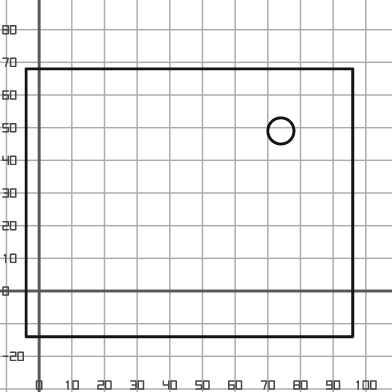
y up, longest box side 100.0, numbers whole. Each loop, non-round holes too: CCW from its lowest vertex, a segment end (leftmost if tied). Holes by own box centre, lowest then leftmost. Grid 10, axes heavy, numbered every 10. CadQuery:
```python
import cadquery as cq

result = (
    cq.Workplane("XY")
    .moveTo(-4.0, -14.0)
    .lineTo(96.0, -14.0)
    .lineTo(96.0, 68.0)
    .lineTo(-4.0, 68.0)
    .close()
    .moveTo(74.0, 49.0)
    .circle(4.0)
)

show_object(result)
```